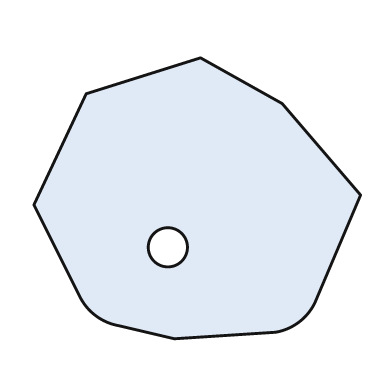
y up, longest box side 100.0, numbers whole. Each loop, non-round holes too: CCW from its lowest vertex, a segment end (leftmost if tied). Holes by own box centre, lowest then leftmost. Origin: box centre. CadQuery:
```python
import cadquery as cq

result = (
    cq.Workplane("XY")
    .moveTo(-7.0, -43.0)
    .lineTo(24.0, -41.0)
    .threePointArc((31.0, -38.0), (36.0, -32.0))
    .lineTo(50.0, 1.0)
    .lineTo(26.0, 29.0)
    .lineTo(1.0, 43.0)
    .lineTo(-34.0, 32.0)
    .lineTo(-50.0, -2.0)
    .lineTo(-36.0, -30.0)
    .threePointArc((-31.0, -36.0), (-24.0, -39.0))
    .close()
    .moveTo(-9.0, -15.0)
    .circle(6.0)
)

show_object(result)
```